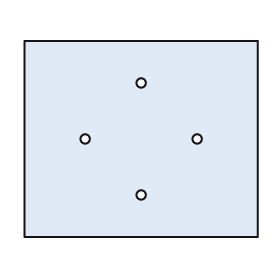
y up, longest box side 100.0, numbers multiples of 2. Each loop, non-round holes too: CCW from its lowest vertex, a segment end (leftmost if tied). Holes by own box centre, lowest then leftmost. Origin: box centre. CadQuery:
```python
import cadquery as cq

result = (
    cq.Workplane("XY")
    .moveTo(-50.0, -42.0)
    .lineTo(50.0, -42.0)
    .lineTo(50.0, 42.0)
    .lineTo(-50.0, 42.0)
    .close()
    .moveTo(0.0, -24.0)
    .circle(2.0)
    .moveTo(-24.0, 0.0)
    .circle(2.0)
    .moveTo(24.0, 0.0)
    .circle(2.0)
    .moveTo(0.0, 24.0)
    .circle(2.0)
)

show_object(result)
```